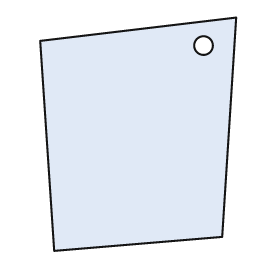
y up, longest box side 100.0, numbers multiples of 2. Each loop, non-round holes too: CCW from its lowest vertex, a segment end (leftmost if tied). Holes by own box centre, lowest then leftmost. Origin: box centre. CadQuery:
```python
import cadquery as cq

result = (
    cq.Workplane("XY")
    .moveTo(-36.0, -50.0)
    .lineTo(36.0, -44.0)
    .lineTo(42.0, 50.0)
    .lineTo(-42.0, 40.0)
    .close()
    .moveTo(28.0, 38.0)
    .circle(4.0)
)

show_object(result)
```